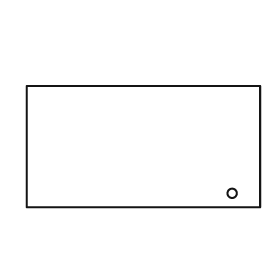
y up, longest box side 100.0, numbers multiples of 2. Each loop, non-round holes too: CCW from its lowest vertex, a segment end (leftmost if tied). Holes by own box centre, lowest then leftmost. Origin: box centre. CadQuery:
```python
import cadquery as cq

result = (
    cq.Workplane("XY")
    .moveTo(-50.0, -26.0)
    .lineTo(50.0, -26.0)
    .lineTo(50.0, 26.0)
    .lineTo(-50.0, 26.0)
    .close()
    .moveTo(38.0, -20.0)
    .circle(2.0)
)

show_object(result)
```